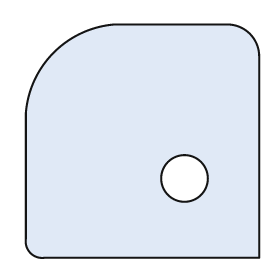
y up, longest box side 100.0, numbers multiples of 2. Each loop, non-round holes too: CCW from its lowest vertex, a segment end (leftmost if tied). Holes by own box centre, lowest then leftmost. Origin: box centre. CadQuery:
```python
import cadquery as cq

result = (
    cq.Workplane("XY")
    .moveTo(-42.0, -50.0)
    .lineTo(50.0, -50.0)
    .lineTo(50.0, 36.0)
    .threePointArc((46.0, 46.0), (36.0, 50.0))
    .lineTo(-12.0, 50.0)
    .threePointArc((-38.0, 38.0), (-50.0, 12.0))
    .lineTo(-50.0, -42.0)
    .threePointArc((-48.0, -48.0), (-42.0, -50.0))
    .close()
    .moveTo(18.0, -16.0)
    .circle(10.0)
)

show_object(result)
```